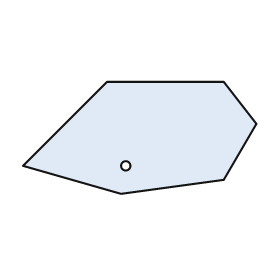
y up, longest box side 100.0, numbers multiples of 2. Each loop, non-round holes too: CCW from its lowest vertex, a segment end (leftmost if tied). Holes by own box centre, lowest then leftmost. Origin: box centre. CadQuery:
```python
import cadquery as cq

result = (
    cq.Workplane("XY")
    .moveTo(-8.0, -24.0)
    .lineTo(36.0, -18.0)
    .lineTo(50.0, 6.0)
    .lineTo(36.0, 24.0)
    .lineTo(-14.0, 24.0)
    .lineTo(-50.0, -12.0)
    .close()
    .moveTo(-6.0, -12.0)
    .circle(2.0)
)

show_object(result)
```